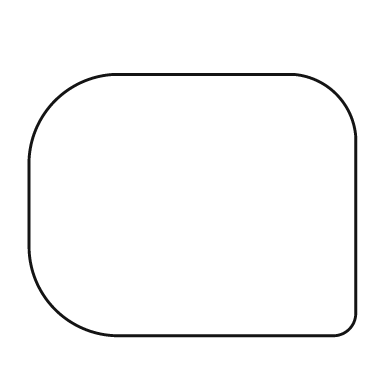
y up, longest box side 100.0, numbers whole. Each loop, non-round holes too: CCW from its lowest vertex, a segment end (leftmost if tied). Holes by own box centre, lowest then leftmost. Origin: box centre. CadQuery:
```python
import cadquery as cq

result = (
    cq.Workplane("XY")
    .moveTo(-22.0, -40.0)
    .lineTo(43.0, -40.0)
    .threePointArc((48.0, -38.0), (50.0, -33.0))
    .lineTo(50.0, 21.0)
    .threePointArc((44.0, 34.0), (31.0, 40.0))
    .lineTo(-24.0, 40.0)
    .threePointArc((-42.0, 32.0), (-50.0, 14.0))
    .lineTo(-50.0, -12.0)
    .threePointArc((-42.0, -32.0), (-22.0, -40.0))
    .close()
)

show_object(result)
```